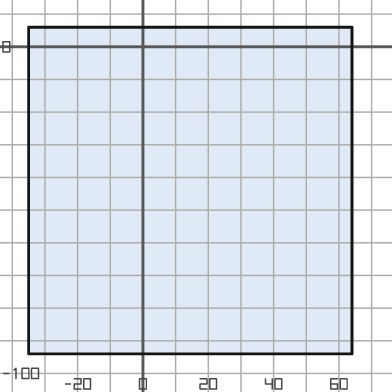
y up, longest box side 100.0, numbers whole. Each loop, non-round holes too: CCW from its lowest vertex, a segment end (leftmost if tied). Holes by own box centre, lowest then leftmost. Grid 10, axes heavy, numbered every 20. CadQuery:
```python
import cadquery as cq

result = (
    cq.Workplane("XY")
    .moveTo(-35.0, -94.0)
    .lineTo(64.0, -94.0)
    .lineTo(64.0, 6.0)
    .lineTo(-35.0, 6.0)
    .close()
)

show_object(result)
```